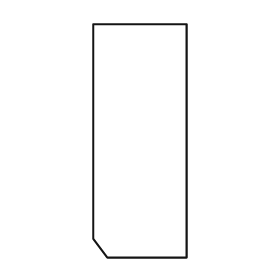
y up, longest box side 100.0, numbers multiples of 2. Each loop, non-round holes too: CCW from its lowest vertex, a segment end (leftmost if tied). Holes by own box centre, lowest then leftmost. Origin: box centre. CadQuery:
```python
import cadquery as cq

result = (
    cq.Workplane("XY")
    .moveTo(-14.0, -50.0)
    .lineTo(20.0, -50.0)
    .lineTo(20.0, 50.0)
    .lineTo(-20.0, 50.0)
    .lineTo(-20.0, -42.0)
    .close()
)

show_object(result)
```